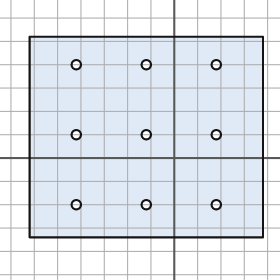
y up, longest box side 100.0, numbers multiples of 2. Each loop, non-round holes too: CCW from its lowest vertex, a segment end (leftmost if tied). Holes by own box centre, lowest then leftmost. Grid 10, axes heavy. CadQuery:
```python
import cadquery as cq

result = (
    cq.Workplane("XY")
    .moveTo(-62.0, -34.0)
    .lineTo(38.0, -34.0)
    .lineTo(38.0, 52.0)
    .lineTo(-62.0, 52.0)
    .close()
    .moveTo(-42.0, -20.0)
    .circle(2.0)
    .moveTo(-12.0, -20.0)
    .circle(2.0)
    .moveTo(18.0, -20.0)
    .circle(2.0)
    .moveTo(-42.0, 10.0)
    .circle(2.0)
    .moveTo(-12.0, 10.0)
    .circle(2.0)
    .moveTo(18.0, 10.0)
    .circle(2.0)
    .moveTo(-42.0, 40.0)
    .circle(2.0)
    .moveTo(-12.0, 40.0)
    .circle(2.0)
    .moveTo(18.0, 40.0)
    .circle(2.0)
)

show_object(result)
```